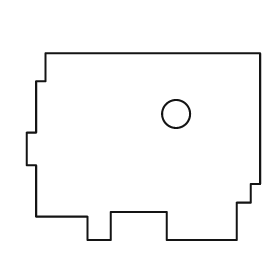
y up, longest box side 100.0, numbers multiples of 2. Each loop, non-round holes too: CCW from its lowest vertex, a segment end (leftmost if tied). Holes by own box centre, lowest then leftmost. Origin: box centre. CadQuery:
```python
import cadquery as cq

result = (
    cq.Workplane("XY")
    .moveTo(-24.0, -40.0)
    .lineTo(-14.0, -40.0)
    .lineTo(-14.0, -28.0)
    .lineTo(10.0, -28.0)
    .lineTo(10.0, -40.0)
    .lineTo(40.0, -40.0)
    .lineTo(40.0, -24.0)
    .lineTo(46.0, -24.0)
    .lineTo(46.0, -16.0)
    .lineTo(50.0, -16.0)
    .lineTo(50.0, 40.0)
    .lineTo(-42.0, 40.0)
    .lineTo(-42.0, 28.0)
    .lineTo(-46.0, 28.0)
    .lineTo(-46.0, 6.0)
    .lineTo(-50.0, 6.0)
    .lineTo(-50.0, -8.0)
    .lineTo(-46.0, -8.0)
    .lineTo(-46.0, -30.0)
    .lineTo(-24.0, -30.0)
    .close()
    .moveTo(14.0, 14.0)
    .circle(6.0)
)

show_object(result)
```